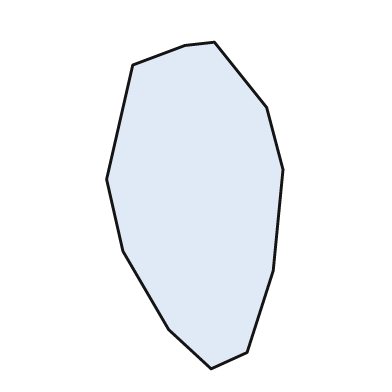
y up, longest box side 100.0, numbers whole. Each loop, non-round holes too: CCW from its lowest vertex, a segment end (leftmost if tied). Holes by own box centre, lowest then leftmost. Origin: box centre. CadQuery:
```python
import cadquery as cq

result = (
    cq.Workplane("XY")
    .moveTo(5.0, -50.0)
    .lineTo(16.0, -45.0)
    .lineTo(24.0, -20.0)
    .lineTo(27.0, 11.0)
    .lineTo(22.0, 30.0)
    .lineTo(6.0, 50.0)
    .lineTo(-3.0, 49.0)
    .lineTo(-19.0, 43.0)
    .lineTo(-27.0, 8.0)
    .lineTo(-22.0, -14.0)
    .lineTo(-8.0, -38.0)
    .close()
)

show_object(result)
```